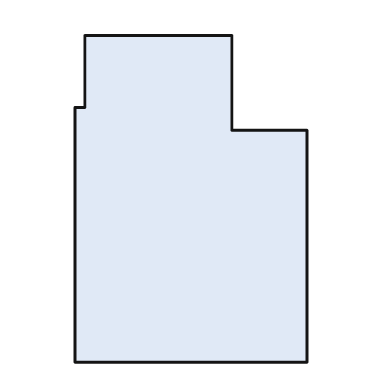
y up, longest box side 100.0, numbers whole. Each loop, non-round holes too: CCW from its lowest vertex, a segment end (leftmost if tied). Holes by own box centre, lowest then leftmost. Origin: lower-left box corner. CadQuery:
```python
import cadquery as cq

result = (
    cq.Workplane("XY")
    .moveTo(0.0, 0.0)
    .lineTo(71.0, 0.0)
    .lineTo(71.0, 71.0)
    .lineTo(48.0, 71.0)
    .lineTo(48.0, 100.0)
    .lineTo(3.0, 100.0)
    .lineTo(3.0, 78.0)
    .lineTo(0.0, 78.0)
    .close()
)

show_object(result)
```